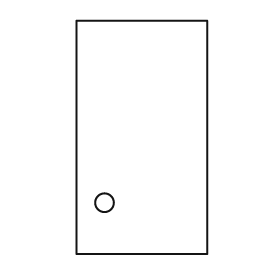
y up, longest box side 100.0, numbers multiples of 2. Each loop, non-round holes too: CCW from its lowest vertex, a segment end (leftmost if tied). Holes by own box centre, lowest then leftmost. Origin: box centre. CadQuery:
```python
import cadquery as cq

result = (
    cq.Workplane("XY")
    .moveTo(-28.0, -50.0)
    .lineTo(28.0, -50.0)
    .lineTo(28.0, 50.0)
    .lineTo(-28.0, 50.0)
    .close()
    .moveTo(-16.0, -28.0)
    .circle(4.0)
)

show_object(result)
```